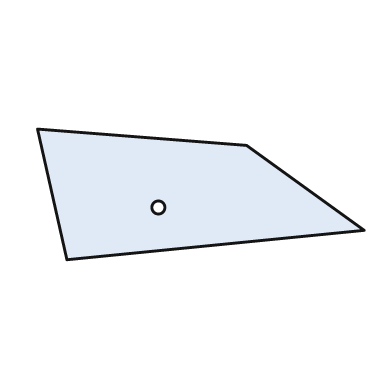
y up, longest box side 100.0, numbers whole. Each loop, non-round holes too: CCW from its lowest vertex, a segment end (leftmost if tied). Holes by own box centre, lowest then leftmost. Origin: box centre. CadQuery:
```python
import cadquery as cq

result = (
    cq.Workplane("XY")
    .moveTo(-41.0, -20.0)
    .lineTo(50.0, -11.0)
    .lineTo(14.0, 15.0)
    .lineTo(-50.0, 20.0)
    .close()
    .moveTo(-13.0, -4.0)
    .circle(2.0)
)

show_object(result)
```